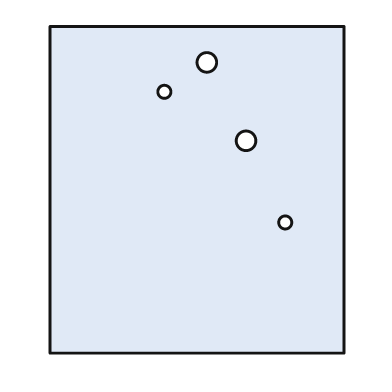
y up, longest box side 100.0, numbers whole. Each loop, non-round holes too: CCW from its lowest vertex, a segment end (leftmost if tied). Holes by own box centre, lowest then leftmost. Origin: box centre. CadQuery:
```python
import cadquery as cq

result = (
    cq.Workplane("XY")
    .moveTo(-45.0, -50.0)
    .lineTo(45.0, -50.0)
    .lineTo(45.0, 50.0)
    .lineTo(-45.0, 50.0)
    .close()
    .moveTo(27.0, -10.0)
    .circle(2.0)
    .moveTo(15.0, 15.0)
    .circle(3.0)
    .moveTo(-10.0, 30.0)
    .circle(2.0)
    .moveTo(3.0, 39.0)
    .circle(3.0)
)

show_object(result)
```